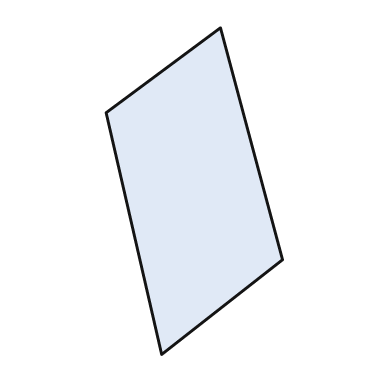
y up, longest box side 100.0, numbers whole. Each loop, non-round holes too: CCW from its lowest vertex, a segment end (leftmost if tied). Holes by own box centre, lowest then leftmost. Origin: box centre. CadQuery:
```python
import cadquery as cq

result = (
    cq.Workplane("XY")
    .moveTo(-10.0, -50.0)
    .lineTo(27.0, -21.0)
    .lineTo(8.0, 50.0)
    .lineTo(-27.0, 24.0)
    .close()
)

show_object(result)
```